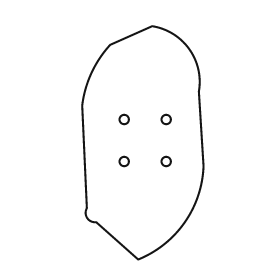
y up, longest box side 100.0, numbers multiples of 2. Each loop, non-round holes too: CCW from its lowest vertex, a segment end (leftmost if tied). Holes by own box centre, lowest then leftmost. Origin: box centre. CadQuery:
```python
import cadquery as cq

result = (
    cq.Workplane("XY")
    .moveTo(-2.0, -50.0)
    .threePointArc((18.0, -34.0), (26.0, -10.0))
    .lineTo(24.0, 22.0)
    .threePointArc((20.0, 40.0), (4.0, 50.0))
    .lineTo(-14.0, 42.0)
    .threePointArc((-22.0, 30.0), (-26.0, 16.0))
    .lineTo(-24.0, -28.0)
    .threePointArc((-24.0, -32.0), (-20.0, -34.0))
    .close()
    .moveTo(-8.0, -8.0)
    .circle(2.0)
    .moveTo(10.0, -8.0)
    .circle(2.0)
    .moveTo(-8.0, 10.0)
    .circle(2.0)
    .moveTo(10.0, 10.0)
    .circle(2.0)
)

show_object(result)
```